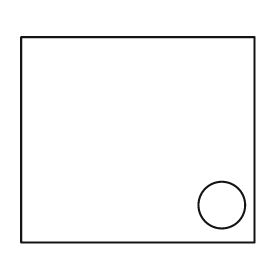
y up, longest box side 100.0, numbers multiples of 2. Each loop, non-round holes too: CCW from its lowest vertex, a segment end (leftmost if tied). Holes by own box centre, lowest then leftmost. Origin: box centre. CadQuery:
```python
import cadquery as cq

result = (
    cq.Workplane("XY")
    .moveTo(-50.0, -44.0)
    .lineTo(50.0, -44.0)
    .lineTo(50.0, 44.0)
    .lineTo(-50.0, 44.0)
    .close()
    .moveTo(36.0, -28.0)
    .circle(10.0)
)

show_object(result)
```